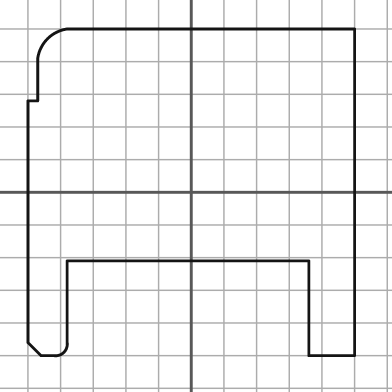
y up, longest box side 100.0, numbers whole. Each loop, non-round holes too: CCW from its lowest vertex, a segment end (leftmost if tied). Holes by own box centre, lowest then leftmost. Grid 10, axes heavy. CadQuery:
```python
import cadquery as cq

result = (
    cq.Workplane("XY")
    .moveTo(-46.0, -50.0)
    .lineTo(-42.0, -50.0)
    .threePointArc((-39.0, -49.0), (-38.0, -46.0))
    .lineTo(-38.0, -21.0)
    .lineTo(36.0, -21.0)
    .lineTo(36.0, -50.0)
    .lineTo(50.0, -50.0)
    .lineTo(50.0, 50.0)
    .lineTo(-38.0, 50.0)
    .threePointArc((-44.0, 47.0), (-47.0, 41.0))
    .lineTo(-47.0, 28.0)
    .lineTo(-50.0, 28.0)
    .lineTo(-50.0, -46.0)
    .close()
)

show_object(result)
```